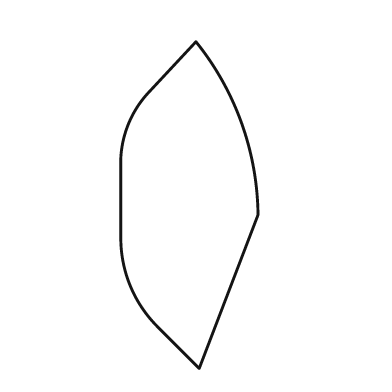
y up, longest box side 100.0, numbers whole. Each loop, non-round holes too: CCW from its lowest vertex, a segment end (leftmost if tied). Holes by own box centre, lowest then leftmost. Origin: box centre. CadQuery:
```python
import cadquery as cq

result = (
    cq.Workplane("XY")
    .moveTo(3.0, -50.0)
    .lineTo(21.0, -3.0)
    .threePointArc((16.0, 25.0), (2.0, 50.0))
    .lineTo(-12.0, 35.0)
    .threePointArc((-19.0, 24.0), (-21.0, 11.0))
    .lineTo(-21.0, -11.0)
    .threePointArc((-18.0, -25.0), (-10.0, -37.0))
    .close()
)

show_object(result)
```